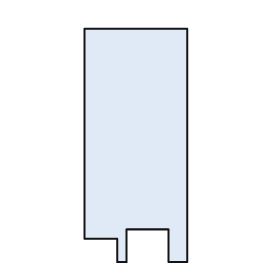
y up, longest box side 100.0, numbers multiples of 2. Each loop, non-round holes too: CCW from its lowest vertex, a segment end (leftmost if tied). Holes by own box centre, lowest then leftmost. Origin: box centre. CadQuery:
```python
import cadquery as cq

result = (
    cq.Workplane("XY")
    .moveTo(-8.0, -50.0)
    .lineTo(-4.0, -50.0)
    .lineTo(-4.0, -36.0)
    .lineTo(14.0, -36.0)
    .lineTo(14.0, -50.0)
    .lineTo(22.0, -50.0)
    .lineTo(22.0, 50.0)
    .lineTo(-22.0, 50.0)
    .lineTo(-22.0, -40.0)
    .lineTo(-8.0, -40.0)
    .close()
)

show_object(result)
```